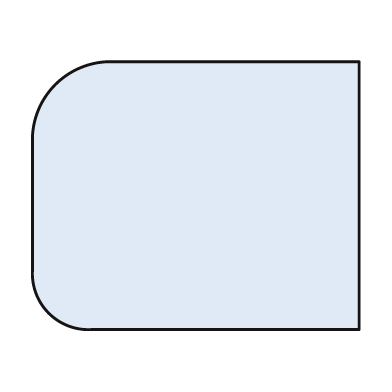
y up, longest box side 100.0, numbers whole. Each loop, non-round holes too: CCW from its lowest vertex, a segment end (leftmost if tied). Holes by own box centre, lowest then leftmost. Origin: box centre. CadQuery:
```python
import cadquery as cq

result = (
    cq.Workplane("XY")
    .moveTo(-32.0, -41.0)
    .lineTo(50.0, -41.0)
    .lineTo(50.0, 41.0)
    .lineTo(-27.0, 41.0)
    .threePointArc((-43.0, 34.0), (-50.0, 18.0))
    .lineTo(-50.0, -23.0)
    .threePointArc((-45.0, -36.0), (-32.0, -41.0))
    .close()
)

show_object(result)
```